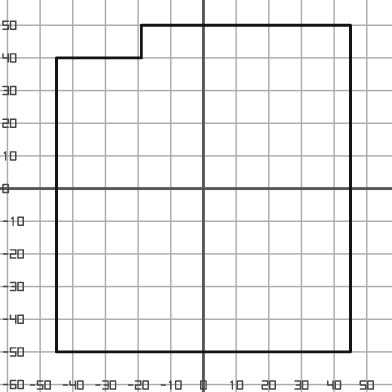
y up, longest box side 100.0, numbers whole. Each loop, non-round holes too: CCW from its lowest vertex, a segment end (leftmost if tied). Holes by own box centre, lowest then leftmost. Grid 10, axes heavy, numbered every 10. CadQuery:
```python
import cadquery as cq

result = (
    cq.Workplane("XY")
    .moveTo(-45.0, -50.0)
    .lineTo(45.0, -50.0)
    .lineTo(45.0, 50.0)
    .lineTo(-19.0, 50.0)
    .lineTo(-19.0, 40.0)
    .lineTo(-45.0, 40.0)
    .close()
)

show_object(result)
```